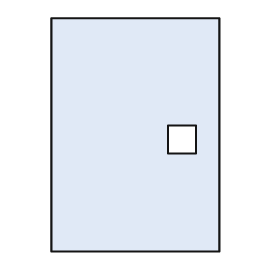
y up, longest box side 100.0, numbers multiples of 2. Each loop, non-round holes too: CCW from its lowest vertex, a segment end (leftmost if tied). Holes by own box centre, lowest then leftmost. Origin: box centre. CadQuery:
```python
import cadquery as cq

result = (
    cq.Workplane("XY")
    .moveTo(-36.0, -50.0)
    .lineTo(36.0, -50.0)
    .lineTo(36.0, 50.0)
    .lineTo(-36.0, 50.0)
    .close()
    .moveTo(14.0, -8.0)
    .lineTo(26.0, -8.0)
    .lineTo(26.0, 4.0)
    .lineTo(14.0, 4.0)
    .close()
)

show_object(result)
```